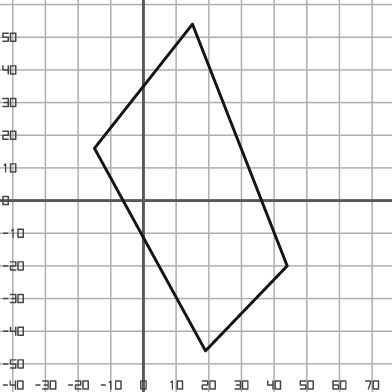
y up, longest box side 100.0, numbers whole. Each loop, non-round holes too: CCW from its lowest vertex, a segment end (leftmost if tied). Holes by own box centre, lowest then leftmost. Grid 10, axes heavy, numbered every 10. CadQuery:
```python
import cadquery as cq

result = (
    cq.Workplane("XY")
    .moveTo(19.0, -46.0)
    .lineTo(44.0, -20.0)
    .lineTo(15.0, 54.0)
    .lineTo(-15.0, 16.0)
    .close()
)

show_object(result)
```